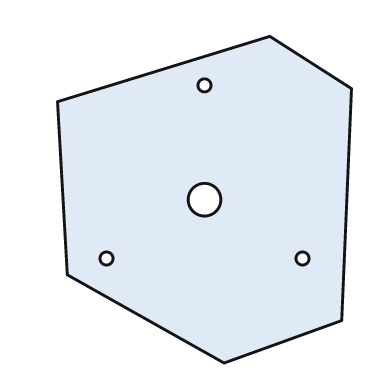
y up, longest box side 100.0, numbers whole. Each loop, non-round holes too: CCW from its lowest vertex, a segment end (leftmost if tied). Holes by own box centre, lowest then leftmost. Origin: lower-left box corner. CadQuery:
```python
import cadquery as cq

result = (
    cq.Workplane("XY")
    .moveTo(51.0, 0.0)
    .lineTo(87.0, 13.0)
    .lineTo(90.0, 84.0)
    .lineTo(65.0, 100.0)
    .lineTo(0.0, 80.0)
    .lineTo(3.0, 27.0)
    .close()
    .moveTo(15.0, 32.0)
    .circle(2.0)
    .moveTo(75.0, 32.0)
    .circle(2.0)
    .moveTo(45.0, 50.0)
    .circle(5.0)
    .moveTo(45.0, 85.0)
    .circle(2.0)
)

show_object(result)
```